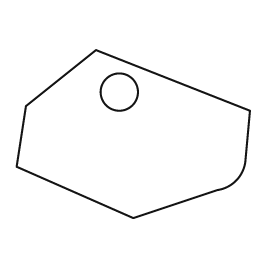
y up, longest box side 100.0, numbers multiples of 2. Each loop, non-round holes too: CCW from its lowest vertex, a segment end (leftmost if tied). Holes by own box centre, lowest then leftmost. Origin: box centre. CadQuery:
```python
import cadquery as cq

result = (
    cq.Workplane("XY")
    .moveTo(0.0, -36.0)
    .lineTo(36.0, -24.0)
    .threePointArc((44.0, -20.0), (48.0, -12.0))
    .lineTo(50.0, 10.0)
    .lineTo(-16.0, 36.0)
    .lineTo(-46.0, 12.0)
    .lineTo(-50.0, -14.0)
    .close()
    .moveTo(-6.0, 18.0)
    .circle(8.0)
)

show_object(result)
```